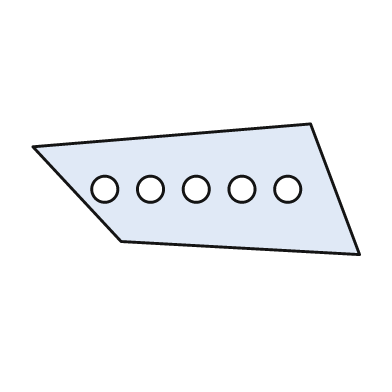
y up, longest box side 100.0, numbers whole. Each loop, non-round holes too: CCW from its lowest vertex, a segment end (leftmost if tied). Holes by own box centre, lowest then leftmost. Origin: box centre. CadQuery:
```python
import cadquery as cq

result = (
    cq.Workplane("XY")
    .moveTo(50.0, -20.0)
    .lineTo(35.0, 20.0)
    .lineTo(-50.0, 13.0)
    .lineTo(-23.0, -16.0)
    .close()
    .moveTo(-28.0, 0.0)
    .circle(4.0)
    .moveTo(-14.0, 0.0)
    .circle(4.0)
    .moveTo(0.0, 0.0)
    .circle(4.0)
    .moveTo(14.0, 0.0)
    .circle(4.0)
    .moveTo(28.0, 0.0)
    .circle(4.0)
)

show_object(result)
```